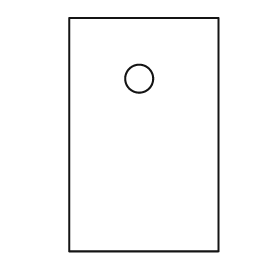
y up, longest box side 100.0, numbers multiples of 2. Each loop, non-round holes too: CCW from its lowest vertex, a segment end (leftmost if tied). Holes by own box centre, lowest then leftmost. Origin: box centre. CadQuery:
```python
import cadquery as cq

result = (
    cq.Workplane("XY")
    .moveTo(-32.0, -50.0)
    .lineTo(32.0, -50.0)
    .lineTo(32.0, 50.0)
    .lineTo(-32.0, 50.0)
    .close()
    .moveTo(-2.0, 24.0)
    .circle(6.0)
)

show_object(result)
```